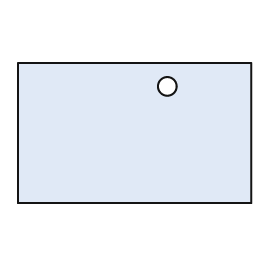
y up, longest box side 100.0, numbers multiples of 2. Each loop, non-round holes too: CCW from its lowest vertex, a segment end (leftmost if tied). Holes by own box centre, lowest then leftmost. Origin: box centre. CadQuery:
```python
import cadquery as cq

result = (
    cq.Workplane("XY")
    .moveTo(-50.0, -30.0)
    .lineTo(50.0, -30.0)
    .lineTo(50.0, 30.0)
    .lineTo(-50.0, 30.0)
    .close()
    .moveTo(14.0, 20.0)
    .circle(4.0)
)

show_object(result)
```